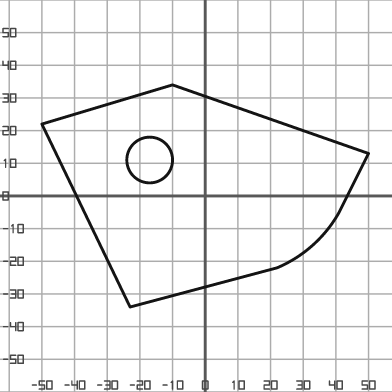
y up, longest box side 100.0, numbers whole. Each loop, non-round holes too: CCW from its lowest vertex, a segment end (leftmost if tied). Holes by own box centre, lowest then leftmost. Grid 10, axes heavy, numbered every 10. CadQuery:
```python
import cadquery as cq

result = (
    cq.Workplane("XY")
    .moveTo(-23.0, -34.0)
    .lineTo(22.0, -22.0)
    .threePointArc((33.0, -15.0), (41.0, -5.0))
    .lineTo(50.0, 13.0)
    .lineTo(-10.0, 34.0)
    .lineTo(-50.0, 22.0)
    .close()
    .moveTo(-17.0, 11.0)
    .circle(7.0)
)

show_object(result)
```